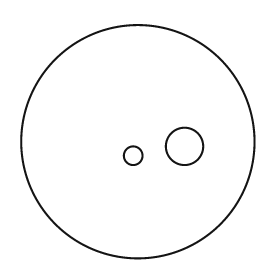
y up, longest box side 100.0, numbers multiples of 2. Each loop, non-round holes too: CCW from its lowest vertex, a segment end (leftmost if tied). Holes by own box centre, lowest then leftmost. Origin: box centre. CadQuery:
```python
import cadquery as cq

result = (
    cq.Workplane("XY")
    .moveTo(0.0, 0.0)
    .circle(50.0)
    .moveTo(-2.0, -6.0)
    .circle(4.0)
    .moveTo(20.0, -2.0)
    .circle(8.0)
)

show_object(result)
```